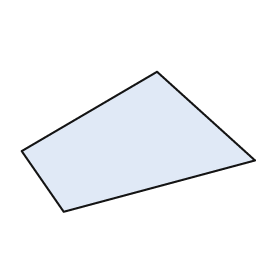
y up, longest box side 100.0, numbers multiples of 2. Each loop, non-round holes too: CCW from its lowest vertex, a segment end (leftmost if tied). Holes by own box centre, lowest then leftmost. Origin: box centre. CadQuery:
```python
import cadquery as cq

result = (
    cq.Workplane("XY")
    .moveTo(-32.0, -30.0)
    .lineTo(50.0, -8.0)
    .lineTo(8.0, 30.0)
    .lineTo(-50.0, -4.0)
    .close()
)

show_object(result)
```